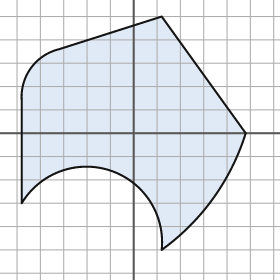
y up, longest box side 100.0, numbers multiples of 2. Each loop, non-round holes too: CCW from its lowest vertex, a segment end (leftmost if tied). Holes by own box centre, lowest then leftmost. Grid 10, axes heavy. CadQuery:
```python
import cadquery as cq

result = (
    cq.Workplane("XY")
    .moveTo(12.0, -50.0)
    .threePointArc((34.0, -28.0), (48.0, 0.0))
    .lineTo(12.0, 50.0)
    .lineTo(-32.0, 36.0)
    .threePointArc((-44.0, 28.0), (-48.0, 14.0))
    .lineTo(-48.0, -30.0)
    .threePointArc((-10.0, -16.0), (12.0, -50.0))
    .close()
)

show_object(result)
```